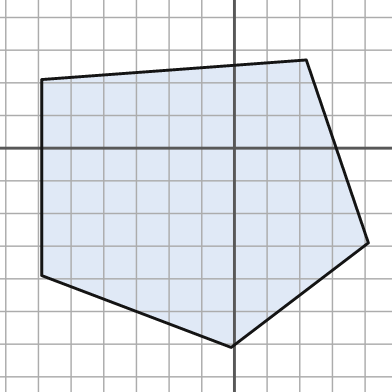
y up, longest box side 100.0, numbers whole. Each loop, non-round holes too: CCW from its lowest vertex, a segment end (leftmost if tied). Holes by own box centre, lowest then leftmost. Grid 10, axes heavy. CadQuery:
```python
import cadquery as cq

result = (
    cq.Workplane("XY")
    .moveTo(-1.0, -61.0)
    .lineTo(41.0, -29.0)
    .lineTo(22.0, 27.0)
    .lineTo(-59.0, 21.0)
    .lineTo(-59.0, -39.0)
    .close()
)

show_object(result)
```